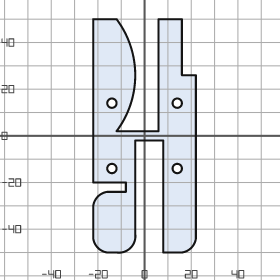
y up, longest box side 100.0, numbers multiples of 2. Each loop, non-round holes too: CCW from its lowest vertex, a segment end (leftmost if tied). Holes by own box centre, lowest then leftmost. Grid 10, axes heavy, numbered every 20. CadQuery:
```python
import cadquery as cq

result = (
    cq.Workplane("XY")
    .moveTo(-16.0, -50.0)
    .lineTo(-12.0, -50.0)
    .threePointArc((-6.0, -48.0), (-4.0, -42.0))
    .lineTo(-4.0, -2.0)
    .lineTo(8.0, -2.0)
    .lineTo(8.0, -50.0)
    .lineTo(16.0, -50.0)
    .threePointArc((20.0, -48.0), (22.0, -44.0))
    .lineTo(22.0, 26.0)
    .lineTo(16.0, 26.0)
    .lineTo(16.0, 50.0)
    .lineTo(6.0, 50.0)
    .lineTo(6.0, 2.0)
    .lineTo(-12.0, 2.0)
    .threePointArc((-4.0, 26.0), (-12.0, 50.0))
    .lineTo(-22.0, 50.0)
    .lineTo(-22.0, -20.0)
    .lineTo(-8.0, -20.0)
    .lineTo(-8.0, -24.0)
    .lineTo(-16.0, -24.0)
    .threePointArc((-20.0, -26.0), (-22.0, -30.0))
    .lineTo(-22.0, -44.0)
    .threePointArc((-20.0, -48.0), (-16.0, -50.0))
    .close()
    .moveTo(-14.0, -14.0)
    .circle(2.0)
    .moveTo(14.0, -14.0)
    .circle(2.0)
    .moveTo(-14.0, 14.0)
    .circle(2.0)
    .moveTo(14.0, 14.0)
    .circle(2.0)
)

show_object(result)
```